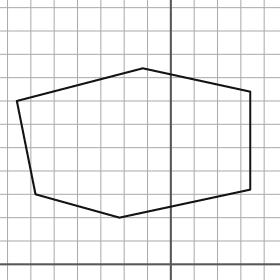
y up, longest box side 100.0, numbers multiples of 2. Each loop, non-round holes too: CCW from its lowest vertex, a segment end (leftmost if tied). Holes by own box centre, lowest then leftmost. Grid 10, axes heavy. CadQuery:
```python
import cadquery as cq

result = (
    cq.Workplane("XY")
    .moveTo(-22.0, 20.0)
    .lineTo(34.0, 32.0)
    .lineTo(34.0, 74.0)
    .lineTo(-12.0, 84.0)
    .lineTo(-66.0, 70.0)
    .lineTo(-58.0, 30.0)
    .close()
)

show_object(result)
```